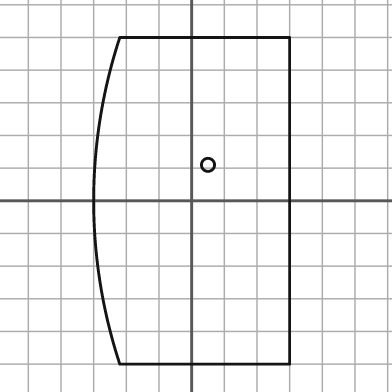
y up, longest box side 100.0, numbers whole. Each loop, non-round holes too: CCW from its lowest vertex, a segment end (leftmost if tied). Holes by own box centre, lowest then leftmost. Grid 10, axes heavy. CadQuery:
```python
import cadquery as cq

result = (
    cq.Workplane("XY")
    .moveTo(-22.0, -50.0)
    .lineTo(30.0, -50.0)
    .lineTo(30.0, 50.0)
    .lineTo(-22.0, 50.0)
    .threePointArc((-30.0, 0.0), (-22.0, -50.0))
    .close()
    .moveTo(5.0, 11.0)
    .circle(2.0)
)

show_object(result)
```